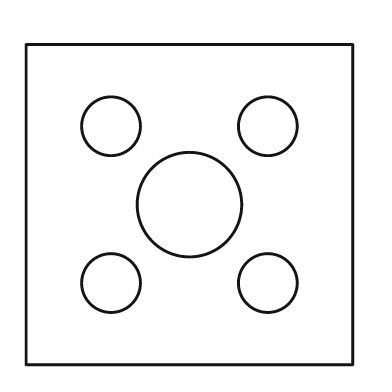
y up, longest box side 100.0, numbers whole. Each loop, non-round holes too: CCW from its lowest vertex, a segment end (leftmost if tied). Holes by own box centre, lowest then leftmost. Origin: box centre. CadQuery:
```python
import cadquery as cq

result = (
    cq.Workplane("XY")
    .moveTo(-50.0, -49.0)
    .lineTo(50.0, -49.0)
    .lineTo(50.0, 49.0)
    .lineTo(-50.0, 49.0)
    .close()
    .moveTo(-24.0, -24.0)
    .circle(9.0)
    .moveTo(24.0, -24.0)
    .circle(9.0)
    .moveTo(0.0, 0.0)
    .circle(16.0)
    .moveTo(-24.0, 24.0)
    .circle(9.0)
    .moveTo(24.0, 24.0)
    .circle(9.0)
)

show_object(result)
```